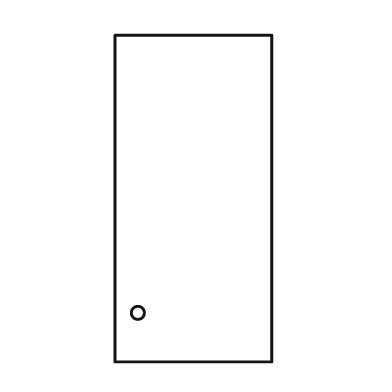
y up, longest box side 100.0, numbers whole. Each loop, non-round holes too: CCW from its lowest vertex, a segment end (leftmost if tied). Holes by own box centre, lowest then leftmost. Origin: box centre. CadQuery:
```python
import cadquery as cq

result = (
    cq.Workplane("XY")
    .moveTo(-24.0, -50.0)
    .lineTo(24.0, -50.0)
    .lineTo(24.0, 50.0)
    .lineTo(-24.0, 50.0)
    .close()
    .moveTo(-17.0, -35.0)
    .circle(2.0)
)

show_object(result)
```